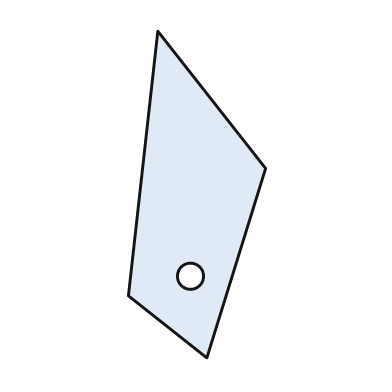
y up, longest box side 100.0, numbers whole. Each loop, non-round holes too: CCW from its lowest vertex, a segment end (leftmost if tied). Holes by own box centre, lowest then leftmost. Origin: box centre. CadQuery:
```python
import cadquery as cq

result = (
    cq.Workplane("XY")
    .moveTo(3.0, -50.0)
    .lineTo(21.0, 8.0)
    .lineTo(-12.0, 50.0)
    .lineTo(-21.0, -31.0)
    .close()
    .moveTo(-2.0, -25.0)
    .circle(4.0)
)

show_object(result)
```